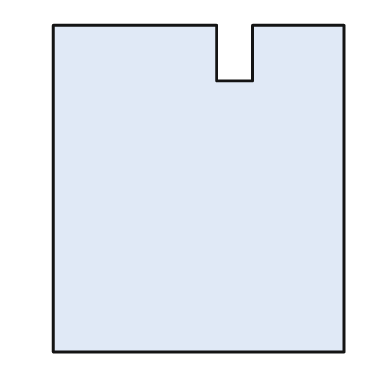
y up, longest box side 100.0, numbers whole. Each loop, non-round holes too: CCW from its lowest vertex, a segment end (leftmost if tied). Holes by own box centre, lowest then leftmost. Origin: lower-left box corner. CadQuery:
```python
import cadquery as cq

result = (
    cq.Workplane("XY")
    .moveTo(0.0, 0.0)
    .lineTo(89.0, 0.0)
    .lineTo(89.0, 100.0)
    .lineTo(61.0, 100.0)
    .lineTo(61.0, 83.0)
    .lineTo(50.0, 83.0)
    .lineTo(50.0, 100.0)
    .lineTo(0.0, 100.0)
    .close()
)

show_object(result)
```